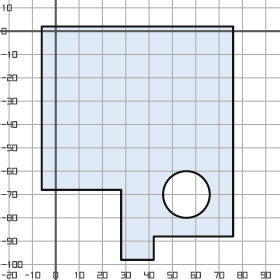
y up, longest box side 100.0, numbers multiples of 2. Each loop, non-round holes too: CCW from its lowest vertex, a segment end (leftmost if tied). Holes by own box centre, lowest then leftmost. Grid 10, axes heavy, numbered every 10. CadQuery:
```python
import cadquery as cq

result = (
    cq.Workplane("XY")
    .moveTo(28.0, -98.0)
    .lineTo(42.0, -98.0)
    .lineTo(42.0, -88.0)
    .lineTo(76.0, -88.0)
    .lineTo(76.0, 2.0)
    .lineTo(-6.0, 2.0)
    .lineTo(-6.0, -68.0)
    .lineTo(28.0, -68.0)
    .close()
    .moveTo(56.0, -70.0)
    .circle(10.0)
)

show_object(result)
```